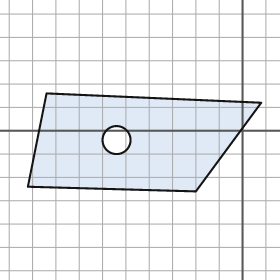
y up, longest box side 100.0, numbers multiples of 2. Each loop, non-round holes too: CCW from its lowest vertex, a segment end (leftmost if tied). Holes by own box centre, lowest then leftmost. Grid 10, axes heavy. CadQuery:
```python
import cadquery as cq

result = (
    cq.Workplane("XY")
    .moveTo(-20.0, -26.0)
    .lineTo(8.0, 12.0)
    .lineTo(-84.0, 16.0)
    .lineTo(-92.0, -24.0)
    .close()
    .moveTo(-54.0, -4.0)
    .circle(6.0)
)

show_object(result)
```